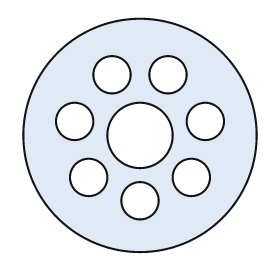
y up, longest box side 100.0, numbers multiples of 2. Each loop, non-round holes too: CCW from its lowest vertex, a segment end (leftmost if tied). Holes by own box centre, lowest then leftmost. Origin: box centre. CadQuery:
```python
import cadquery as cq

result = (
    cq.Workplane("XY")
    .moveTo(0.0, 0.0)
    .circle(50.0)
    .moveTo(0.0, -28.0)
    .circle(8.0)
    .moveTo(-22.0, -18.0)
    .circle(8.0)
    .moveTo(22.0, -18.0)
    .circle(8.0)
    .moveTo(0.0, 0.0)
    .circle(14.0)
    .moveTo(-28.0, 6.0)
    .circle(8.0)
    .moveTo(28.0, 6.0)
    .circle(8.0)
    .moveTo(-12.0, 26.0)
    .circle(8.0)
    .moveTo(12.0, 26.0)
    .circle(8.0)
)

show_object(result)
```